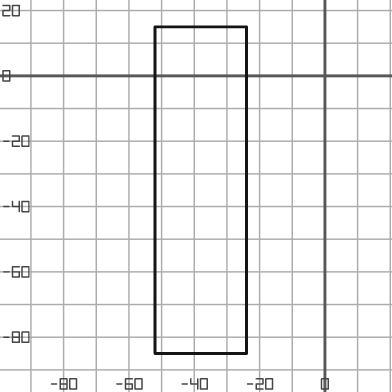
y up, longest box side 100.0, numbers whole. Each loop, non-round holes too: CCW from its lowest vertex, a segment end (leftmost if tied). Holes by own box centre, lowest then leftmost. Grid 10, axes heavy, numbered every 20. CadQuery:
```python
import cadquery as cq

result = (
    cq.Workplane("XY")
    .moveTo(-52.0, -85.0)
    .lineTo(-24.0, -85.0)
    .lineTo(-24.0, 15.0)
    .lineTo(-52.0, 15.0)
    .close()
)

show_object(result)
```